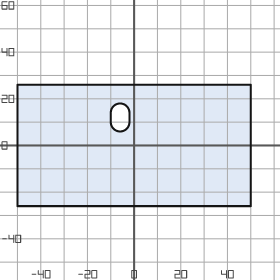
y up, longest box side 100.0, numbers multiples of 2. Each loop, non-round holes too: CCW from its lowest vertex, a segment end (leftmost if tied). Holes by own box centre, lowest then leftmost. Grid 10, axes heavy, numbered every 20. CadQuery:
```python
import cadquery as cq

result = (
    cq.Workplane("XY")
    .moveTo(-50.0, -26.0)
    .lineTo(50.0, -26.0)
    .lineTo(50.0, 26.0)
    .lineTo(-50.0, 26.0)
    .close()
    .moveTo(-10.0, 10.0)
    .threePointArc((-6.0, 6.0), (-2.0, 10.0))
    .lineTo(-2.0, 14.0)
    .threePointArc((-6.0, 18.0), (-10.0, 14.0))
    .close()
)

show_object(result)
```